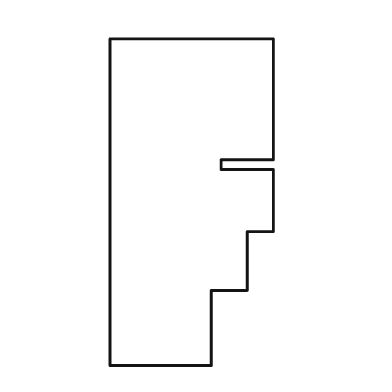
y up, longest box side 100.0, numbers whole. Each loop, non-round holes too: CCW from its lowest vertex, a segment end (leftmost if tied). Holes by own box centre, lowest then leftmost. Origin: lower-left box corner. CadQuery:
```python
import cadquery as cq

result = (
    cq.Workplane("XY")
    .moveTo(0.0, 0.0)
    .lineTo(31.0, 0.0)
    .lineTo(31.0, 23.0)
    .lineTo(42.0, 23.0)
    .lineTo(42.0, 41.0)
    .lineTo(50.0, 41.0)
    .lineTo(50.0, 60.0)
    .lineTo(34.0, 60.0)
    .lineTo(34.0, 63.0)
    .lineTo(50.0, 63.0)
    .lineTo(50.0, 100.0)
    .lineTo(0.0, 100.0)
    .close()
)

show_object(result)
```